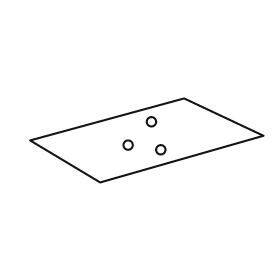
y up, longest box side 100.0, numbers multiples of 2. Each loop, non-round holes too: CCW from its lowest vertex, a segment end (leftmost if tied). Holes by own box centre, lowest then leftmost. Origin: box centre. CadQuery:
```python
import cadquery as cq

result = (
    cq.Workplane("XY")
    .moveTo(-20.0, -18.0)
    .lineTo(50.0, 2.0)
    .lineTo(16.0, 18.0)
    .lineTo(-50.0, 0.0)
    .close()
    .moveTo(6.0, -4.0)
    .circle(2.0)
    .moveTo(-8.0, -2.0)
    .circle(2.0)
    .moveTo(2.0, 8.0)
    .circle(2.0)
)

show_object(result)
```